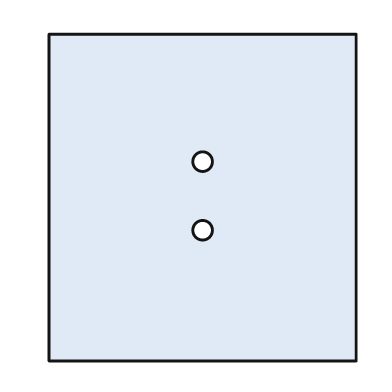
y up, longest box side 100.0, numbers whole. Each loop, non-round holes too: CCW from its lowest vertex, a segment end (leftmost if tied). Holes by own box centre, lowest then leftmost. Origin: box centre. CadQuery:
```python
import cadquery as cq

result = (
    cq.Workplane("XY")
    .moveTo(-47.0, -50.0)
    .lineTo(47.0, -50.0)
    .lineTo(47.0, 50.0)
    .lineTo(-47.0, 50.0)
    .close()
    .moveTo(0.0, -10.0)
    .circle(3.0)
    .moveTo(0.0, 11.0)
    .circle(3.0)
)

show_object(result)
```